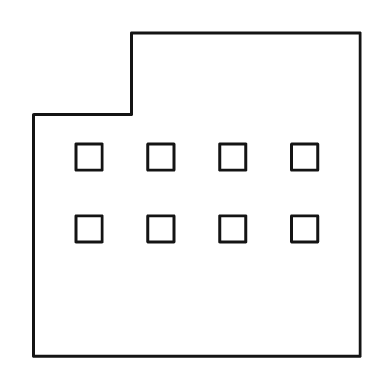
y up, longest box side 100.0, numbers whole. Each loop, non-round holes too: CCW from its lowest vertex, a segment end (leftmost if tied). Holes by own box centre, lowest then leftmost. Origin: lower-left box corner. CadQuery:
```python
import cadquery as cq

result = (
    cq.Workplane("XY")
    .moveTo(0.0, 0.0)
    .lineTo(100.0, 0.0)
    .lineTo(100.0, 99.0)
    .lineTo(30.0, 99.0)
    .lineTo(30.0, 74.0)
    .lineTo(0.0, 74.0)
    .close()
    .moveTo(13.0, 35.0)
    .lineTo(21.0, 35.0)
    .lineTo(21.0, 43.0)
    .lineTo(13.0, 43.0)
    .close()
    .moveTo(35.0, 35.0)
    .lineTo(43.0, 35.0)
    .lineTo(43.0, 43.0)
    .lineTo(35.0, 43.0)
    .close()
    .moveTo(57.0, 35.0)
    .lineTo(65.0, 35.0)
    .lineTo(65.0, 43.0)
    .lineTo(57.0, 43.0)
    .close()
    .moveTo(79.0, 35.0)
    .lineTo(87.0, 35.0)
    .lineTo(87.0, 43.0)
    .lineTo(79.0, 43.0)
    .close()
    .moveTo(13.0, 57.0)
    .lineTo(21.0, 57.0)
    .lineTo(21.0, 65.0)
    .lineTo(13.0, 65.0)
    .close()
    .moveTo(35.0, 57.0)
    .lineTo(43.0, 57.0)
    .lineTo(43.0, 65.0)
    .lineTo(35.0, 65.0)
    .close()
    .moveTo(57.0, 57.0)
    .lineTo(65.0, 57.0)
    .lineTo(65.0, 65.0)
    .lineTo(57.0, 65.0)
    .close()
    .moveTo(79.0, 57.0)
    .lineTo(87.0, 57.0)
    .lineTo(87.0, 65.0)
    .lineTo(79.0, 65.0)
    .close()
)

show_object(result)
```